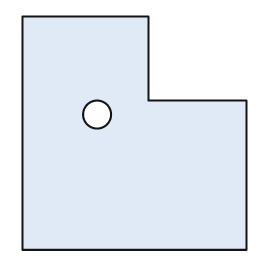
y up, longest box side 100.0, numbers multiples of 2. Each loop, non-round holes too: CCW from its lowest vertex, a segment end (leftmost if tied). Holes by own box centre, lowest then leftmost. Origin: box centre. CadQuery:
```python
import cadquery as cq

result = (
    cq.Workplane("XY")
    .moveTo(-48.0, -50.0)
    .lineTo(48.0, -50.0)
    .lineTo(48.0, 14.0)
    .lineTo(6.0, 14.0)
    .lineTo(6.0, 50.0)
    .lineTo(-48.0, 50.0)
    .close()
    .moveTo(-16.0, 8.0)
    .circle(6.0)
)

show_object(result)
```